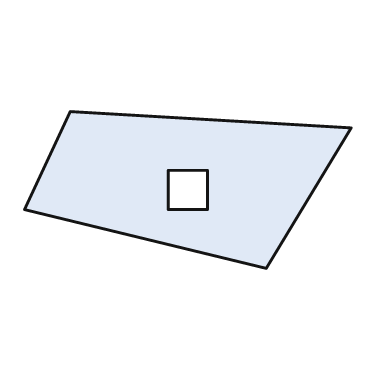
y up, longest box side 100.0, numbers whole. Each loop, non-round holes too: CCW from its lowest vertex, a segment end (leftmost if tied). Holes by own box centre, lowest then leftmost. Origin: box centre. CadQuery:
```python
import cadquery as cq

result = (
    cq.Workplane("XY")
    .moveTo(24.0, -24.0)
    .lineTo(50.0, 19.0)
    .lineTo(-36.0, 24.0)
    .lineTo(-50.0, -6.0)
    .close()
    .moveTo(-6.0, -6.0)
    .lineTo(6.0, -6.0)
    .lineTo(6.0, 6.0)
    .lineTo(-6.0, 6.0)
    .close()
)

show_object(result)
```